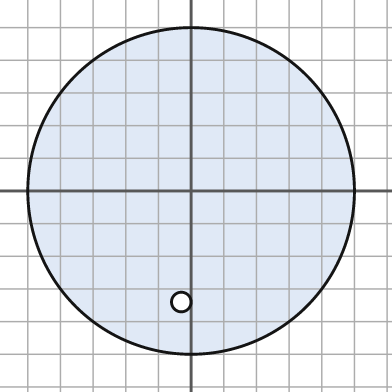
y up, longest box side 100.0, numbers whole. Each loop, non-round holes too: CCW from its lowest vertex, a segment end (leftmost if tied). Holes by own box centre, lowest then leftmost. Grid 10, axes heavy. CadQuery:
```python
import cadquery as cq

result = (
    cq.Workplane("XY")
    .moveTo(0.0, 0.0)
    .circle(50.0)
    .moveTo(-3.0, -34.0)
    .circle(3.0)
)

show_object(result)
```